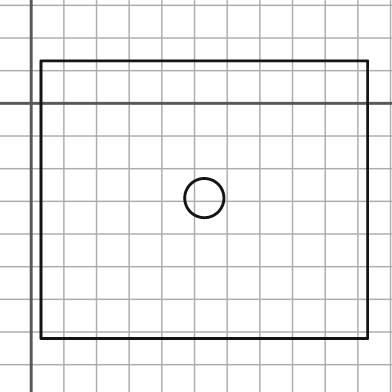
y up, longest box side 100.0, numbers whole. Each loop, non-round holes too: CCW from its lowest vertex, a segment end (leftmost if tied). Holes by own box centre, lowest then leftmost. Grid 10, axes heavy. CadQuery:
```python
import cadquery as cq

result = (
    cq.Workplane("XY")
    .moveTo(3.0, -72.0)
    .lineTo(103.0, -72.0)
    .lineTo(103.0, 13.0)
    .lineTo(3.0, 13.0)
    .close()
    .moveTo(53.0, -29.0)
    .circle(6.0)
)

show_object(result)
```